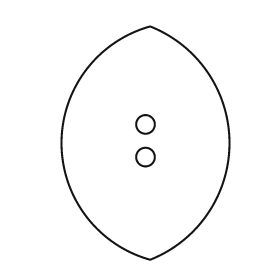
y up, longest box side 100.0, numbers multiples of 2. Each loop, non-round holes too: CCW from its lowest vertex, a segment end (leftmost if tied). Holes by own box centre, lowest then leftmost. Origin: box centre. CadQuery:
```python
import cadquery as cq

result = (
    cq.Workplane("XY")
    .moveTo(2.0, -50.0)
    .threePointArc((36.0, 0.0), (2.0, 50.0))
    .threePointArc((-36.0, 0.0), (2.0, -50.0))
    .close()
    .moveTo(0.0, -6.0)
    .circle(4.0)
    .moveTo(0.0, 8.0)
    .circle(4.0)
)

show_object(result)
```